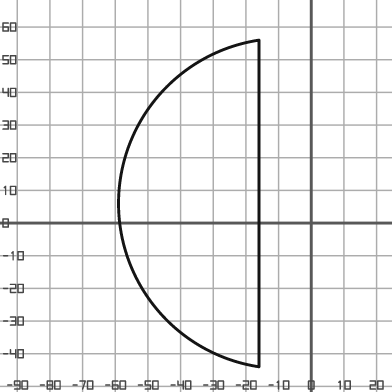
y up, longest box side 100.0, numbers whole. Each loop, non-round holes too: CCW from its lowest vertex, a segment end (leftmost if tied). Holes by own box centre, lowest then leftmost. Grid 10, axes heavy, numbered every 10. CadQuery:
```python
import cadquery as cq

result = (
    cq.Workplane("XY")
    .moveTo(-16.0, -44.0)
    .lineTo(-16.0, 56.0)
    .threePointArc((-59.0, 6.0), (-16.0, -44.0))
    .close()
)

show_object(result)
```